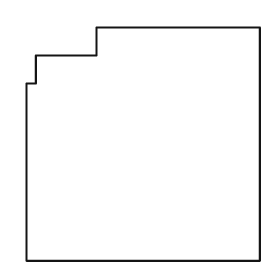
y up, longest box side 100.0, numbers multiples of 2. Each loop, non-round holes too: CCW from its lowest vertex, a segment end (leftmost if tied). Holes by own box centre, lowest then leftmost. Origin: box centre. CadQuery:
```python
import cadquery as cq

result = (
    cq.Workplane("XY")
    .moveTo(-50.0, -50.0)
    .lineTo(50.0, -50.0)
    .lineTo(50.0, 50.0)
    .lineTo(-20.0, 50.0)
    .lineTo(-20.0, 38.0)
    .lineTo(-46.0, 38.0)
    .lineTo(-46.0, 26.0)
    .lineTo(-50.0, 26.0)
    .close()
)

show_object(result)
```